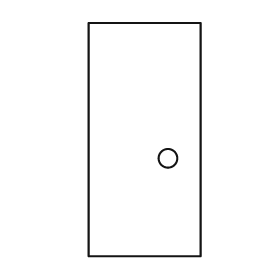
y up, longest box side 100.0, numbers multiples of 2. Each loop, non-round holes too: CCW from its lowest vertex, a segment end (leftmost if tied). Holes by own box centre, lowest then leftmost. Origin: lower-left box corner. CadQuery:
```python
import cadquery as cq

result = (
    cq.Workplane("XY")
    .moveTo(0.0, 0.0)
    .lineTo(48.0, 0.0)
    .lineTo(48.0, 100.0)
    .lineTo(0.0, 100.0)
    .close()
    .moveTo(34.0, 42.0)
    .circle(4.0)
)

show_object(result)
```